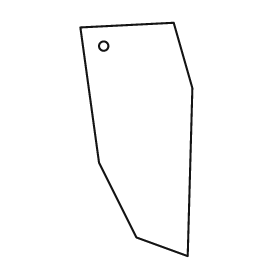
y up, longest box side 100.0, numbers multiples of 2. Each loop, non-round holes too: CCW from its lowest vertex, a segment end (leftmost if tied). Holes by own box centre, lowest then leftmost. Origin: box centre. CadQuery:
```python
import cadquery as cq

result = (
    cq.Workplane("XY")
    .moveTo(22.0, -50.0)
    .lineTo(24.0, 22.0)
    .lineTo(16.0, 50.0)
    .lineTo(-24.0, 48.0)
    .lineTo(-16.0, -10.0)
    .lineTo(0.0, -42.0)
    .close()
    .moveTo(-14.0, 40.0)
    .circle(2.0)
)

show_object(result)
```